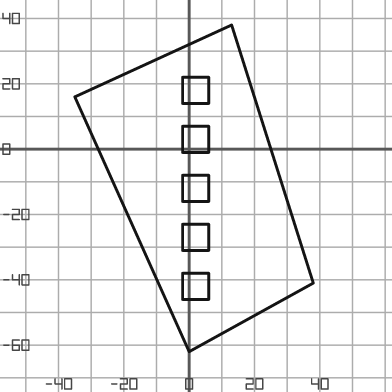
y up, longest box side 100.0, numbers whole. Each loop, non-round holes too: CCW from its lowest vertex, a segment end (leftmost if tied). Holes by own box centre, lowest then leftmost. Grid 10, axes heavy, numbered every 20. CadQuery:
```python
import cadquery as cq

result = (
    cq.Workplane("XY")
    .moveTo(0.0, -62.0)
    .lineTo(38.0, -41.0)
    .lineTo(13.0, 38.0)
    .lineTo(-35.0, 16.0)
    .close()
    .moveTo(-2.0, -46.0)
    .lineTo(6.0, -46.0)
    .lineTo(6.0, -38.0)
    .lineTo(-2.0, -38.0)
    .close()
    .moveTo(-2.0, -31.0)
    .lineTo(6.0, -31.0)
    .lineTo(6.0, -23.0)
    .lineTo(-2.0, -23.0)
    .close()
    .moveTo(-2.0, -16.0)
    .lineTo(6.0, -16.0)
    .lineTo(6.0, -8.0)
    .lineTo(-2.0, -8.0)
    .close()
    .moveTo(-2.0, -1.0)
    .lineTo(6.0, -1.0)
    .lineTo(6.0, 7.0)
    .lineTo(-2.0, 7.0)
    .close()
    .moveTo(-2.0, 14.0)
    .lineTo(6.0, 14.0)
    .lineTo(6.0, 22.0)
    .lineTo(-2.0, 22.0)
    .close()
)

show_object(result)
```